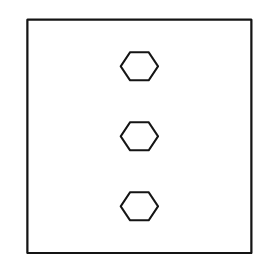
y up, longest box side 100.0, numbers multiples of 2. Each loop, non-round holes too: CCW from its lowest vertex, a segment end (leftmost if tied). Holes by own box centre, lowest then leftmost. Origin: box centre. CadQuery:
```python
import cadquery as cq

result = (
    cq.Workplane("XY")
    .moveTo(-48.0, -50.0)
    .lineTo(48.0, -50.0)
    .lineTo(48.0, 50.0)
    .lineTo(-48.0, 50.0)
    .close()
    .moveTo(-4.0, -36.0)
    .lineTo(4.0, -36.0)
    .lineTo(8.0, -30.0)
    .lineTo(4.0, -24.0)
    .lineTo(-4.0, -24.0)
    .lineTo(-8.0, -30.0)
    .close()
    .moveTo(-4.0, -6.0)
    .lineTo(4.0, -6.0)
    .lineTo(8.0, 0.0)
    .lineTo(4.0, 6.0)
    .lineTo(-4.0, 6.0)
    .lineTo(-8.0, 0.0)
    .close()
    .moveTo(-4.0, 24.0)
    .lineTo(4.0, 24.0)
    .lineTo(8.0, 30.0)
    .lineTo(4.0, 36.0)
    .lineTo(-4.0, 36.0)
    .lineTo(-8.0, 30.0)
    .close()
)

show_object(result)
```